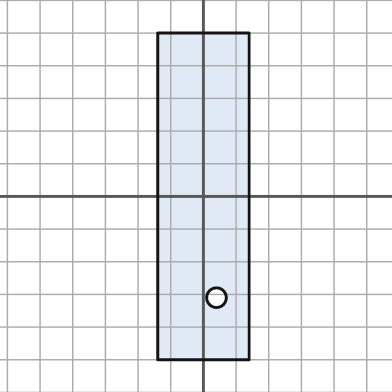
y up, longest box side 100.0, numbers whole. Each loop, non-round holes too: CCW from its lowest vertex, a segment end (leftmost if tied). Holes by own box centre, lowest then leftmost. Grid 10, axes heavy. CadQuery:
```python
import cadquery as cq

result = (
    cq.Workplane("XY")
    .moveTo(-14.0, -50.0)
    .lineTo(14.0, -50.0)
    .lineTo(14.0, 50.0)
    .lineTo(-14.0, 50.0)
    .close()
    .moveTo(4.0, -31.0)
    .circle(3.0)
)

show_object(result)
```